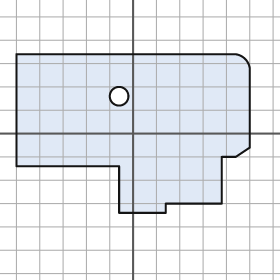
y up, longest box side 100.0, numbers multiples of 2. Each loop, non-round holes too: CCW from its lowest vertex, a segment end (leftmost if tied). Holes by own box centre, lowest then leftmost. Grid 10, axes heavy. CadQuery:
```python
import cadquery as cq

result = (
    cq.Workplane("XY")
    .moveTo(-6.0, -34.0)
    .lineTo(14.0, -34.0)
    .lineTo(14.0, -30.0)
    .lineTo(38.0, -30.0)
    .lineTo(38.0, -10.0)
    .lineTo(44.0, -10.0)
    .lineTo(50.0, -6.0)
    .lineTo(50.0, 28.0)
    .threePointArc((48.0, 32.0), (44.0, 34.0))
    .lineTo(-50.0, 34.0)
    .lineTo(-50.0, -14.0)
    .lineTo(-6.0, -14.0)
    .close()
    .moveTo(-6.0, 16.0)
    .circle(4.0)
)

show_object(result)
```